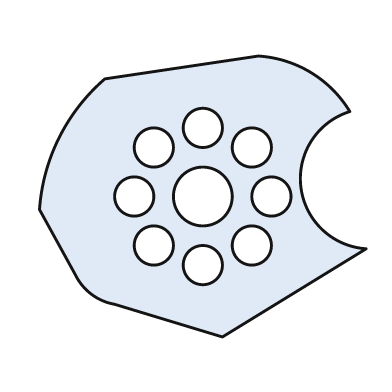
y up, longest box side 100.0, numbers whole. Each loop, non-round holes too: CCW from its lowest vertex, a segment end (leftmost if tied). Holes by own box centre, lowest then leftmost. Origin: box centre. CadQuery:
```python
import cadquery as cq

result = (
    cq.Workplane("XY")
    .moveTo(6.0, -43.0)
    .lineTo(50.0, -16.0)
    .threePointArc((30.0, 3.0), (45.0, 26.0))
    .threePointArc((33.0, 38.0), (17.0, 43.0))
    .lineTo(-30.0, 36.0)
    .threePointArc((-44.0, 18.0), (-50.0, -4.0))
    .lineTo(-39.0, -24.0)
    .threePointArc((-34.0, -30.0), (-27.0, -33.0))
    .close()
    .moveTo(0.0, -21.0)
    .circle(6.0)
    .moveTo(-15.0, -15.0)
    .circle(6.0)
    .moveTo(15.0, -15.0)
    .circle(6.0)
    .moveTo(-21.0, 0.0)
    .circle(6.0)
    .moveTo(0.0, 0.0)
    .circle(9.0)
    .moveTo(21.0, 0.0)
    .circle(6.0)
    .moveTo(-15.0, 15.0)
    .circle(6.0)
    .moveTo(15.0, 15.0)
    .circle(6.0)
    .moveTo(0.0, 21.0)
    .circle(6.0)
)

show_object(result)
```